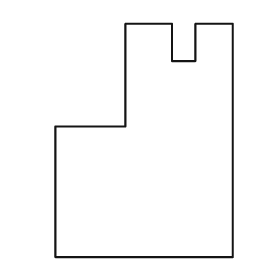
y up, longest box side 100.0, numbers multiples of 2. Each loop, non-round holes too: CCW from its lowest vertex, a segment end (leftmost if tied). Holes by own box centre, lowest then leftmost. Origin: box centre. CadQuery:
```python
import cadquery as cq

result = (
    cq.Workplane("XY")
    .moveTo(-38.0, -50.0)
    .lineTo(38.0, -50.0)
    .lineTo(38.0, 50.0)
    .lineTo(22.0, 50.0)
    .lineTo(22.0, 34.0)
    .lineTo(12.0, 34.0)
    .lineTo(12.0, 50.0)
    .lineTo(-8.0, 50.0)
    .lineTo(-8.0, 6.0)
    .lineTo(-38.0, 6.0)
    .close()
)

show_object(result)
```